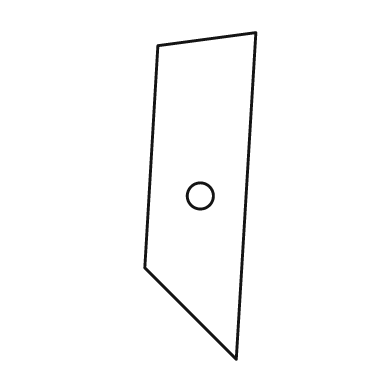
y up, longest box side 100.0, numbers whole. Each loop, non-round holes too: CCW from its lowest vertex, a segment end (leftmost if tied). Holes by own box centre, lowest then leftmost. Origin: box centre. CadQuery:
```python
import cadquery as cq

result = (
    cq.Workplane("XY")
    .moveTo(11.0, -50.0)
    .lineTo(17.0, 50.0)
    .lineTo(-13.0, 46.0)
    .lineTo(-17.0, -22.0)
    .close()
    .moveTo(0.0, 0.0)
    .circle(4.0)
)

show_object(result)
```